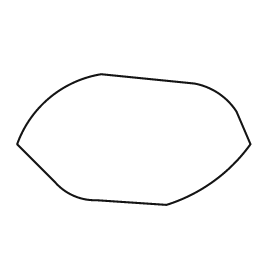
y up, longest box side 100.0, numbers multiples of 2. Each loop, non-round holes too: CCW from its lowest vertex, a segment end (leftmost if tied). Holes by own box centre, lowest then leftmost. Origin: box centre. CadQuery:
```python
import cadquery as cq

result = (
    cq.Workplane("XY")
    .moveTo(14.0, -28.0)
    .threePointArc((34.0, -18.0), (50.0, -2.0))
    .lineTo(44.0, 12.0)
    .threePointArc((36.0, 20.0), (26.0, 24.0))
    .lineTo(-14.0, 28.0)
    .threePointArc((-36.0, 18.0), (-50.0, -2.0))
    .lineTo(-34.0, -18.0)
    .threePointArc((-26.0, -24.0), (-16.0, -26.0))
    .close()
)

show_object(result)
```